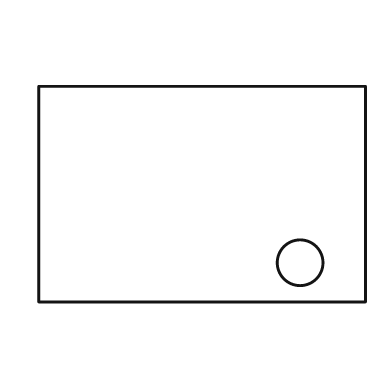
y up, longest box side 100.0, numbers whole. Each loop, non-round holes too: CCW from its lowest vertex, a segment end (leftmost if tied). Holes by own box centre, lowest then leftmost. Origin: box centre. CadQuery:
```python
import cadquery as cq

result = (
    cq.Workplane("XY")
    .moveTo(-50.0, -33.0)
    .lineTo(50.0, -33.0)
    .lineTo(50.0, 33.0)
    .lineTo(-50.0, 33.0)
    .close()
    .moveTo(30.0, -21.0)
    .circle(7.0)
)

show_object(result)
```